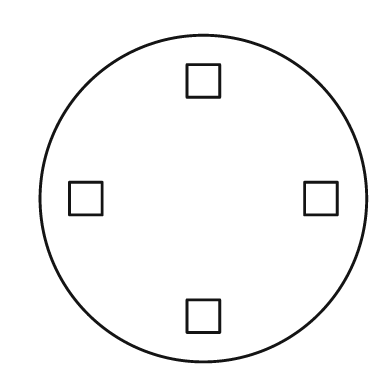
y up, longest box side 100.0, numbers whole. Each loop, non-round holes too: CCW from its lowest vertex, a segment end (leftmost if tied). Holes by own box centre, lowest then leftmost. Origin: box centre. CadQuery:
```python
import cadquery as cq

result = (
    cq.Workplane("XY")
    .moveTo(0.0, 0.0)
    .circle(50.0)
    .moveTo(-5.0, -41.0)
    .lineTo(5.0, -41.0)
    .lineTo(5.0, -31.0)
    .lineTo(-5.0, -31.0)
    .close()
    .moveTo(-41.0, -5.0)
    .lineTo(-31.0, -5.0)
    .lineTo(-31.0, 5.0)
    .lineTo(-41.0, 5.0)
    .close()
    .moveTo(31.0, -5.0)
    .lineTo(41.0, -5.0)
    .lineTo(41.0, 5.0)
    .lineTo(31.0, 5.0)
    .close()
    .moveTo(-5.0, 31.0)
    .lineTo(5.0, 31.0)
    .lineTo(5.0, 41.0)
    .lineTo(-5.0, 41.0)
    .close()
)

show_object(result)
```